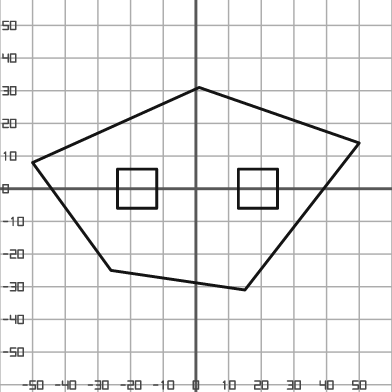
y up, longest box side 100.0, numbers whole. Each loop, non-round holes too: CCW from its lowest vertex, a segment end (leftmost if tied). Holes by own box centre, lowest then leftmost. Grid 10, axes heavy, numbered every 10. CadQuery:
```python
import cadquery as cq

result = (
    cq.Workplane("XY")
    .moveTo(15.0, -31.0)
    .lineTo(50.0, 14.0)
    .lineTo(1.0, 31.0)
    .lineTo(-50.0, 8.0)
    .lineTo(-26.0, -25.0)
    .close()
    .moveTo(-24.0, -6.0)
    .lineTo(-12.0, -6.0)
    .lineTo(-12.0, 6.0)
    .lineTo(-24.0, 6.0)
    .close()
    .moveTo(13.0, -6.0)
    .lineTo(25.0, -6.0)
    .lineTo(25.0, 6.0)
    .lineTo(13.0, 6.0)
    .close()
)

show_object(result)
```